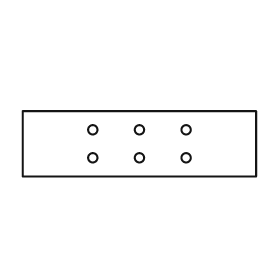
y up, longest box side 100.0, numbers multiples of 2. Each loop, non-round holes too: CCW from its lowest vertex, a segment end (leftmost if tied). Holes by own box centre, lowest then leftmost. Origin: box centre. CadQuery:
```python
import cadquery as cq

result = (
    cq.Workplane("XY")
    .moveTo(-50.0, -14.0)
    .lineTo(50.0, -14.0)
    .lineTo(50.0, 14.0)
    .lineTo(-50.0, 14.0)
    .close()
    .moveTo(-20.0, -6.0)
    .circle(2.0)
    .moveTo(0.0, -6.0)
    .circle(2.0)
    .moveTo(20.0, -6.0)
    .circle(2.0)
    .moveTo(-20.0, 6.0)
    .circle(2.0)
    .moveTo(0.0, 6.0)
    .circle(2.0)
    .moveTo(20.0, 6.0)
    .circle(2.0)
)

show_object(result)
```